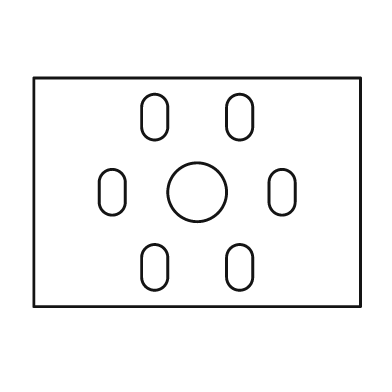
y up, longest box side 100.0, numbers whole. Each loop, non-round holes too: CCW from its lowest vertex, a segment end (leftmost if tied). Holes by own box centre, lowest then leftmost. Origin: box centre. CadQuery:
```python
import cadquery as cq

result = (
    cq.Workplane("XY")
    .moveTo(-50.0, -35.0)
    .lineTo(50.0, -35.0)
    .lineTo(50.0, 35.0)
    .lineTo(-50.0, 35.0)
    .close()
    .moveTo(-17.0, -26.0)
    .threePointArc((-13.0, -30.0), (-9.0, -26.0))
    .lineTo(-9.0, -20.0)
    .threePointArc((-13.0, -16.0), (-17.0, -20.0))
    .close()
    .moveTo(9.0, -26.0)
    .threePointArc((13.0, -30.0), (17.0, -26.0))
    .lineTo(17.0, -20.0)
    .threePointArc((13.0, -16.0), (9.0, -20.0))
    .close()
    .moveTo(-30.0, -3.0)
    .threePointArc((-26.0, -7.0), (-22.0, -3.0))
    .lineTo(-22.0, 3.0)
    .threePointArc((-26.0, 7.0), (-30.0, 3.0))
    .close()
    .moveTo(0.0, 0.0)
    .circle(9.0)
    .moveTo(22.0, -3.0)
    .threePointArc((26.0, -7.0), (30.0, -3.0))
    .lineTo(30.0, 3.0)
    .threePointArc((26.0, 7.0), (22.0, 3.0))
    .close()
    .moveTo(-17.0, 20.0)
    .threePointArc((-13.0, 16.0), (-9.0, 20.0))
    .lineTo(-9.0, 26.0)
    .threePointArc((-13.0, 30.0), (-17.0, 26.0))
    .close()
    .moveTo(9.0, 20.0)
    .threePointArc((13.0, 16.0), (17.0, 20.0))
    .lineTo(17.0, 26.0)
    .threePointArc((13.0, 30.0), (9.0, 26.0))
    .close()
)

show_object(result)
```